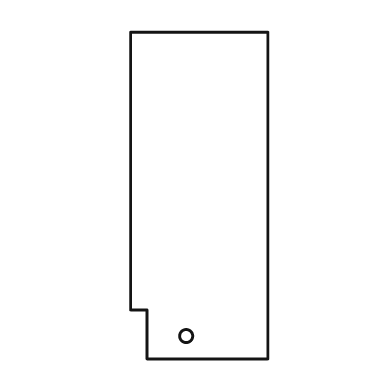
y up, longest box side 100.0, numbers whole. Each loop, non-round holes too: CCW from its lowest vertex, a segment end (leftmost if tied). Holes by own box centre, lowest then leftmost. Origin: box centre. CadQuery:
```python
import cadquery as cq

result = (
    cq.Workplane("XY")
    .moveTo(-16.0, -50.0)
    .lineTo(21.0, -50.0)
    .lineTo(21.0, 50.0)
    .lineTo(-21.0, 50.0)
    .lineTo(-21.0, -35.0)
    .lineTo(-16.0, -35.0)
    .close()
    .moveTo(-4.0, -43.0)
    .circle(2.0)
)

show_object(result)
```